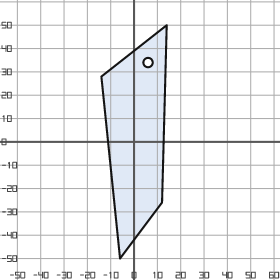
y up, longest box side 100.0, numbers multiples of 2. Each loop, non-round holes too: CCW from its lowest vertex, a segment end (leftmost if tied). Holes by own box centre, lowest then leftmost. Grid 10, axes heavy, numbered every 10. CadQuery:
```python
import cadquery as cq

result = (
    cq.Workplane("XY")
    .moveTo(-6.0, -50.0)
    .lineTo(12.0, -26.0)
    .lineTo(14.0, 50.0)
    .lineTo(-14.0, 28.0)
    .close()
    .moveTo(6.0, 34.0)
    .circle(2.0)
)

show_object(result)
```